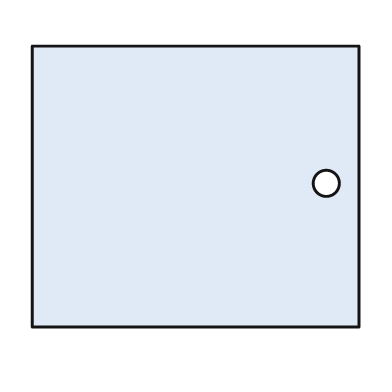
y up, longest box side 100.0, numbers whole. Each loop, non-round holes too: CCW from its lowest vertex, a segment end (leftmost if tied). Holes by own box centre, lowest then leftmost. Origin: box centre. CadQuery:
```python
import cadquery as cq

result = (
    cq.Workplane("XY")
    .moveTo(-50.0, -43.0)
    .lineTo(50.0, -43.0)
    .lineTo(50.0, 43.0)
    .lineTo(-50.0, 43.0)
    .close()
    .moveTo(40.0, 1.0)
    .circle(4.0)
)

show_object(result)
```